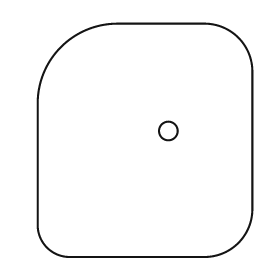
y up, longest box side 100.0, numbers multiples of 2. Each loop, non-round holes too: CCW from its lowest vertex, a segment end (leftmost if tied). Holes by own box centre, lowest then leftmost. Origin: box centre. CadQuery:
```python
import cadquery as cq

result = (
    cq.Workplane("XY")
    .moveTo(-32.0, -50.0)
    .lineTo(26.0, -50.0)
    .threePointArc((40.0, -44.0), (46.0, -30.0))
    .lineTo(46.0, 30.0)
    .threePointArc((40.0, 44.0), (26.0, 50.0))
    .lineTo(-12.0, 50.0)
    .threePointArc((-36.0, 40.0), (-46.0, 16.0))
    .lineTo(-46.0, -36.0)
    .threePointArc((-42.0, -46.0), (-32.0, -50.0))
    .close()
    .moveTo(10.0, 4.0)
    .circle(4.0)
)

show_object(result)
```